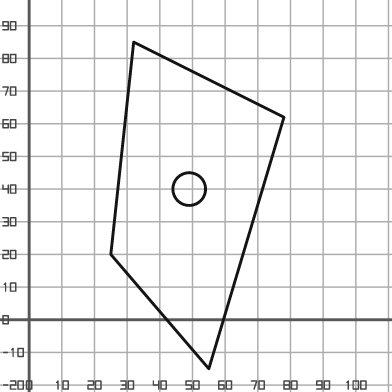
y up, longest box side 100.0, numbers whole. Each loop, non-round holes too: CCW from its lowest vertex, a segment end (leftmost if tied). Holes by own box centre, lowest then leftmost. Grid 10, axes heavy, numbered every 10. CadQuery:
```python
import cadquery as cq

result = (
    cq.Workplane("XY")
    .moveTo(55.0, -15.0)
    .lineTo(78.0, 62.0)
    .lineTo(32.0, 85.0)
    .lineTo(25.0, 20.0)
    .close()
    .moveTo(49.0, 40.0)
    .circle(5.0)
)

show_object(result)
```